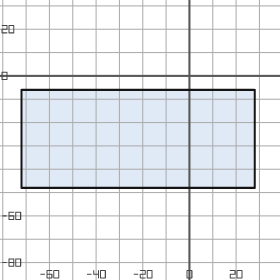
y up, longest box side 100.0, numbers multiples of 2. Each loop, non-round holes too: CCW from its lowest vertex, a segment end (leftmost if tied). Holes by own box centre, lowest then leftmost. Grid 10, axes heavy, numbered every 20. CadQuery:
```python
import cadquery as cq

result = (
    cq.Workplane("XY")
    .moveTo(-72.0, -48.0)
    .lineTo(28.0, -48.0)
    .lineTo(28.0, -6.0)
    .lineTo(-72.0, -6.0)
    .close()
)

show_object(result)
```